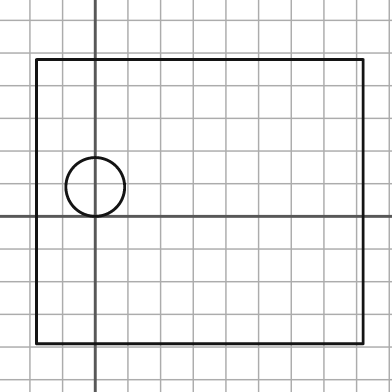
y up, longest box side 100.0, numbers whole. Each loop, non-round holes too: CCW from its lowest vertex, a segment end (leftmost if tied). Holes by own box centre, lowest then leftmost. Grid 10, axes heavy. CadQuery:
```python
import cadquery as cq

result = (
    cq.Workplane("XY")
    .moveTo(-18.0, -39.0)
    .lineTo(82.0, -39.0)
    .lineTo(82.0, 48.0)
    .lineTo(-18.0, 48.0)
    .close()
    .moveTo(0.0, 9.0)
    .circle(9.0)
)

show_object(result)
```